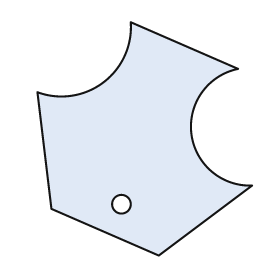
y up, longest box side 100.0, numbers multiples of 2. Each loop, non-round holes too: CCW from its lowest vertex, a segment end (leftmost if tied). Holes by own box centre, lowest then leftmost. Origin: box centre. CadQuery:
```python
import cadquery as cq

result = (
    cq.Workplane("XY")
    .moveTo(6.0, -50.0)
    .lineTo(46.0, -20.0)
    .threePointArc((20.0, 2.0), (40.0, 30.0))
    .lineTo(-6.0, 50.0)
    .threePointArc((-18.0, 24.0), (-46.0, 20.0))
    .lineTo(-40.0, -30.0)
    .close()
    .moveTo(-10.0, -28.0)
    .circle(4.0)
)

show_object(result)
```